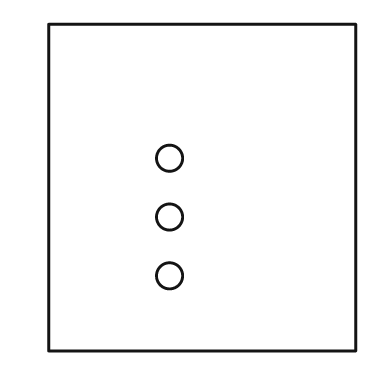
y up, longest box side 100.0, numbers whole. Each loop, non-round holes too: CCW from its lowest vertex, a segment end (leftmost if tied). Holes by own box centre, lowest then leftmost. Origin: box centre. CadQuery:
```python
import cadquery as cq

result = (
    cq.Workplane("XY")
    .moveTo(-47.0, -50.0)
    .lineTo(47.0, -50.0)
    .lineTo(47.0, 50.0)
    .lineTo(-47.0, 50.0)
    .close()
    .moveTo(-10.0, -27.0)
    .circle(4.0)
    .moveTo(-10.0, -9.0)
    .circle(4.0)
    .moveTo(-10.0, 9.0)
    .circle(4.0)
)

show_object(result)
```